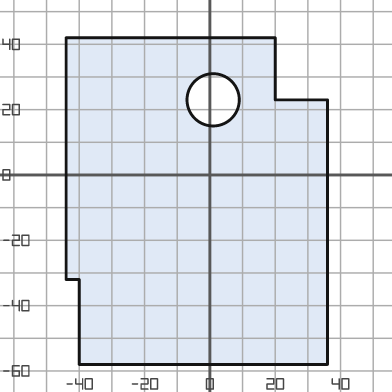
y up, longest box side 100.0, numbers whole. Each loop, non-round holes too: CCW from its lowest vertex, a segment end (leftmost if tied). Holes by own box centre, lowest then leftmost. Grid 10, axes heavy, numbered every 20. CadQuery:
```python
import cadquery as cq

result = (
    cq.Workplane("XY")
    .moveTo(-40.0, -58.0)
    .lineTo(36.0, -58.0)
    .lineTo(36.0, 23.0)
    .lineTo(20.0, 23.0)
    .lineTo(20.0, 42.0)
    .lineTo(-44.0, 42.0)
    .lineTo(-44.0, -32.0)
    .lineTo(-40.0, -32.0)
    .close()
    .moveTo(1.0, 23.0)
    .circle(8.0)
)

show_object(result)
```